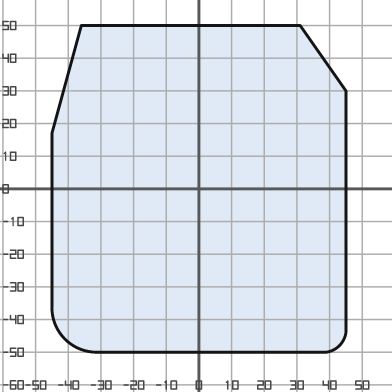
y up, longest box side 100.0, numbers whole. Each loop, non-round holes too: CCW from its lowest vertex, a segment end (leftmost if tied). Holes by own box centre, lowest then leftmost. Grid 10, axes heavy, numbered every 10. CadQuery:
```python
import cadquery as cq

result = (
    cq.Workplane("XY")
    .moveTo(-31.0, -50.0)
    .lineTo(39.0, -50.0)
    .threePointArc((43.0, -48.0), (45.0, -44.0))
    .lineTo(45.0, 30.0)
    .lineTo(31.0, 50.0)
    .lineTo(-36.0, 50.0)
    .lineTo(-45.0, 17.0)
    .lineTo(-45.0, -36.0)
    .threePointArc((-41.0, -46.0), (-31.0, -50.0))
    .close()
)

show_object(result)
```